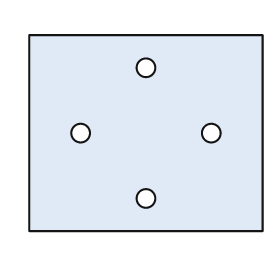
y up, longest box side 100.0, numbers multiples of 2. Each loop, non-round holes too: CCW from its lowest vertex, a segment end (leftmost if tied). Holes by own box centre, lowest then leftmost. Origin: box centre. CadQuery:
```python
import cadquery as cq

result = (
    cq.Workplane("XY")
    .moveTo(-50.0, -42.0)
    .lineTo(50.0, -42.0)
    .lineTo(50.0, 42.0)
    .lineTo(-50.0, 42.0)
    .close()
    .moveTo(0.0, -28.0)
    .circle(4.0)
    .moveTo(-28.0, 0.0)
    .circle(4.0)
    .moveTo(28.0, 0.0)
    .circle(4.0)
    .moveTo(0.0, 28.0)
    .circle(4.0)
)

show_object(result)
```